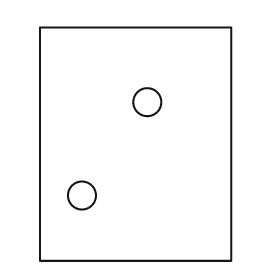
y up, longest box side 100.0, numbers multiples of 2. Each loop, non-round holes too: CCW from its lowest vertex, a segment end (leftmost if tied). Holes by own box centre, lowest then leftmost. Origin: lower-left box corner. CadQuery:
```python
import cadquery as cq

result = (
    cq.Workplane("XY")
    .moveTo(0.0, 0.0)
    .lineTo(82.0, 0.0)
    .lineTo(82.0, 100.0)
    .lineTo(0.0, 100.0)
    .close()
    .moveTo(18.0, 28.0)
    .circle(6.0)
    .moveTo(46.0, 68.0)
    .circle(6.0)
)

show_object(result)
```